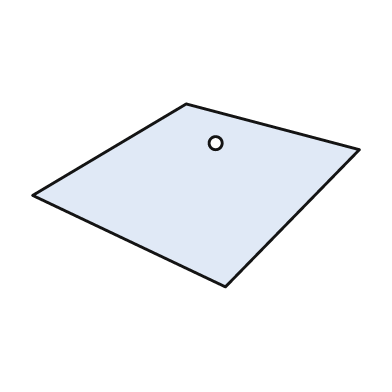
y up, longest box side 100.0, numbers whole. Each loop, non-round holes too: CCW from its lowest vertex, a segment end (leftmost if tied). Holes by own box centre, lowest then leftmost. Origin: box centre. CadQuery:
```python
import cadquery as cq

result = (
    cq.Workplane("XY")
    .moveTo(9.0, -28.0)
    .lineTo(50.0, 14.0)
    .lineTo(-3.0, 28.0)
    .lineTo(-50.0, 0.0)
    .close()
    .moveTo(6.0, 16.0)
    .circle(2.0)
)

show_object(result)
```